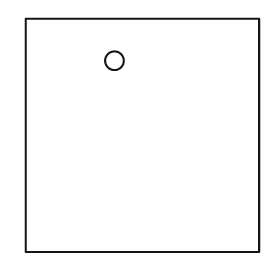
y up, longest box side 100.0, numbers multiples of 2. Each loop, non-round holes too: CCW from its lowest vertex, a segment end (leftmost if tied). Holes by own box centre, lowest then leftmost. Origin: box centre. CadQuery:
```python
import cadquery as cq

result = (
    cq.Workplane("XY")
    .moveTo(-50.0, -50.0)
    .lineTo(50.0, -50.0)
    .lineTo(50.0, 50.0)
    .lineTo(-50.0, 50.0)
    .close()
    .moveTo(-12.0, 32.0)
    .circle(4.0)
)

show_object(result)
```